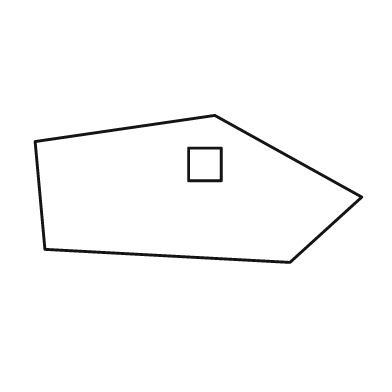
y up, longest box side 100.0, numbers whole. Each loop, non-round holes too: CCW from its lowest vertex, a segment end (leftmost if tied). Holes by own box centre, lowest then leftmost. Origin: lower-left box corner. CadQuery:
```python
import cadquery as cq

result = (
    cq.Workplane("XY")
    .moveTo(78.0, 0.0)
    .lineTo(100.0, 20.0)
    .lineTo(55.0, 45.0)
    .lineTo(0.0, 37.0)
    .lineTo(3.0, 4.0)
    .close()
    .moveTo(47.0, 25.0)
    .lineTo(57.0, 25.0)
    .lineTo(57.0, 35.0)
    .lineTo(47.0, 35.0)
    .close()
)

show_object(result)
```